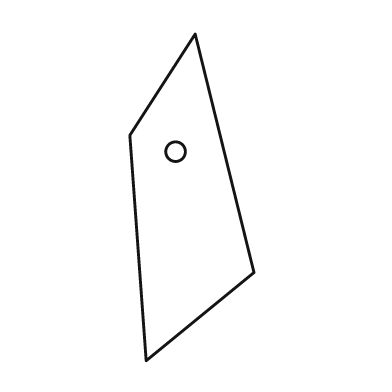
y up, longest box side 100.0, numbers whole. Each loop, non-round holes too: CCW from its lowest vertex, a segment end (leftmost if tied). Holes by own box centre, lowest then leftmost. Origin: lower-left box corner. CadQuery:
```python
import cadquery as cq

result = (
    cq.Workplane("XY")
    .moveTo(5.0, 0.0)
    .lineTo(38.0, 27.0)
    .lineTo(20.0, 100.0)
    .lineTo(0.0, 69.0)
    .close()
    .moveTo(14.0, 64.0)
    .circle(3.0)
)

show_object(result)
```